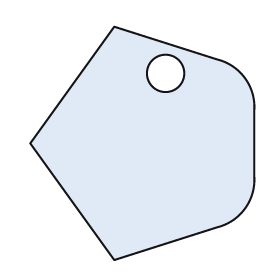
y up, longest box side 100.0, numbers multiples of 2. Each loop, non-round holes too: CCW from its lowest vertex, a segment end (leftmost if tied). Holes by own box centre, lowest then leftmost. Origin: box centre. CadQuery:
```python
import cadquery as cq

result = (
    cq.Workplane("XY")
    .moveTo(-12.0, -50.0)
    .lineTo(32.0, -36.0)
    .threePointArc((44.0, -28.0), (48.0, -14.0))
    .lineTo(48.0, 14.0)
    .threePointArc((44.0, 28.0), (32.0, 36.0))
    .lineTo(-12.0, 50.0)
    .lineTo(-48.0, 0.0)
    .close()
    .moveTo(10.0, 30.0)
    .circle(8.0)
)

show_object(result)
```